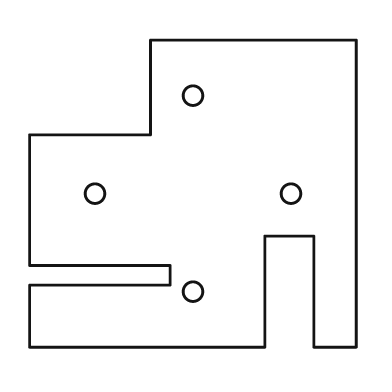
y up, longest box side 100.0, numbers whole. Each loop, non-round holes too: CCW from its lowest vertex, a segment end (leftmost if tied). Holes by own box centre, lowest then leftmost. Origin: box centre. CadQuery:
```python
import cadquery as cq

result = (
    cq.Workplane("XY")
    .moveTo(-50.0, -47.0)
    .lineTo(22.0, -47.0)
    .lineTo(22.0, -13.0)
    .lineTo(37.0, -13.0)
    .lineTo(37.0, -47.0)
    .lineTo(50.0, -47.0)
    .lineTo(50.0, 47.0)
    .lineTo(-13.0, 47.0)
    .lineTo(-13.0, 18.0)
    .lineTo(-50.0, 18.0)
    .lineTo(-50.0, -22.0)
    .lineTo(-7.0, -22.0)
    .lineTo(-7.0, -28.0)
    .lineTo(-50.0, -28.0)
    .close()
    .moveTo(0.0, -30.0)
    .circle(3.0)
    .moveTo(-30.0, 0.0)
    .circle(3.0)
    .moveTo(30.0, 0.0)
    .circle(3.0)
    .moveTo(0.0, 30.0)
    .circle(3.0)
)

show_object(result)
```